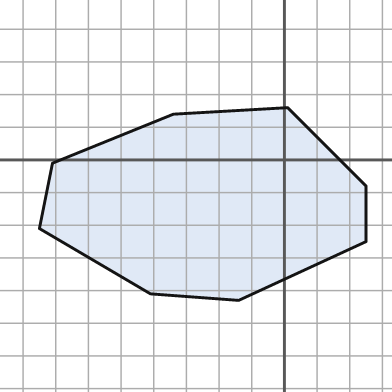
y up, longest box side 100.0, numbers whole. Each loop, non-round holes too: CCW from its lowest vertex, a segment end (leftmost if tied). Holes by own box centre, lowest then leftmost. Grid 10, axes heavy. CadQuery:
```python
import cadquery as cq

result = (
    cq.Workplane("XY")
    .moveTo(-14.0, -43.0)
    .lineTo(25.0, -25.0)
    .lineTo(25.0, -8.0)
    .lineTo(1.0, 16.0)
    .lineTo(-34.0, 14.0)
    .lineTo(-71.0, -1.0)
    .lineTo(-75.0, -21.0)
    .lineTo(-41.0, -41.0)
    .close()
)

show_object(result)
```